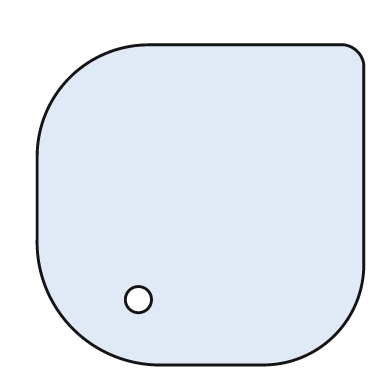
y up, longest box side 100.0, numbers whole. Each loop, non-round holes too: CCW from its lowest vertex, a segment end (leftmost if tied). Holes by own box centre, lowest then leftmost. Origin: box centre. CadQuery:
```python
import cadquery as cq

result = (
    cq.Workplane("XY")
    .moveTo(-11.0, -49.0)
    .lineTo(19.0, -49.0)
    .threePointArc((41.0, -40.0), (50.0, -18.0))
    .lineTo(50.0, 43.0)
    .threePointArc((48.0, 47.0), (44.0, 49.0))
    .lineTo(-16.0, 49.0)
    .threePointArc((-40.0, 39.0), (-50.0, 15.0))
    .lineTo(-50.0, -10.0)
    .threePointArc((-39.0, -38.0), (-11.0, -49.0))
    .close()
    .moveTo(-19.0, -29.0)
    .circle(4.0)
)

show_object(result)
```